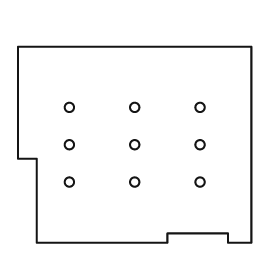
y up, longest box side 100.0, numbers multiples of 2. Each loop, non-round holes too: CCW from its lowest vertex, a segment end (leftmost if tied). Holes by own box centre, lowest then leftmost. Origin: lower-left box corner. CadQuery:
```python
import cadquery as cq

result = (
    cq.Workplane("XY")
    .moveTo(8.0, 0.0)
    .lineTo(64.0, 0.0)
    .lineTo(64.0, 4.0)
    .lineTo(90.0, 4.0)
    .lineTo(90.0, 0.0)
    .lineTo(100.0, 0.0)
    .lineTo(100.0, 84.0)
    .lineTo(0.0, 84.0)
    .lineTo(0.0, 36.0)
    .lineTo(8.0, 36.0)
    .close()
    .moveTo(22.0, 26.0)
    .circle(2.0)
    .moveTo(50.0, 26.0)
    .circle(2.0)
    .moveTo(78.0, 26.0)
    .circle(2.0)
    .moveTo(22.0, 42.0)
    .circle(2.0)
    .moveTo(50.0, 42.0)
    .circle(2.0)
    .moveTo(78.0, 42.0)
    .circle(2.0)
    .moveTo(22.0, 58.0)
    .circle(2.0)
    .moveTo(50.0, 58.0)
    .circle(2.0)
    .moveTo(78.0, 58.0)
    .circle(2.0)
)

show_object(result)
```